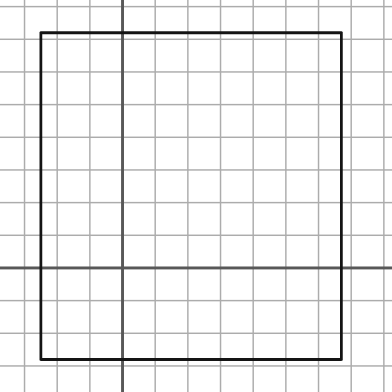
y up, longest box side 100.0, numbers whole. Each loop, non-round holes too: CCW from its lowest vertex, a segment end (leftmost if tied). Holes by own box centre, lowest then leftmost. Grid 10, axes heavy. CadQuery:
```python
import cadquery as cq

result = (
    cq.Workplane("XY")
    .moveTo(-25.0, -28.0)
    .lineTo(67.0, -28.0)
    .lineTo(67.0, 72.0)
    .lineTo(-25.0, 72.0)
    .close()
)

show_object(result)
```